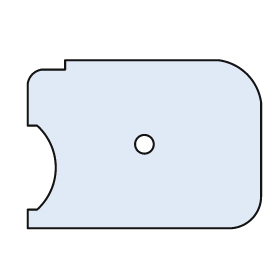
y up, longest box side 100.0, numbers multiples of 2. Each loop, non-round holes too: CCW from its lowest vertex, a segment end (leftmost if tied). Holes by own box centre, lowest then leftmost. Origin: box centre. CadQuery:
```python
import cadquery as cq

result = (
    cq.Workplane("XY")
    .moveTo(-50.0, -36.0)
    .lineTo(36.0, -36.0)
    .threePointArc((46.0, -32.0), (50.0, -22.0))
    .lineTo(50.0, 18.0)
    .threePointArc((44.0, 30.0), (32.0, 36.0))
    .lineTo(-34.0, 36.0)
    .lineTo(-34.0, 32.0)
    .lineTo(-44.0, 32.0)
    .threePointArc((-48.0, 30.0), (-50.0, 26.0))
    .lineTo(-50.0, 8.0)
    .lineTo(-46.0, 8.0)
    .threePointArc((-38.0, -10.0), (-46.0, -28.0))
    .lineTo(-50.0, -28.0)
    .close()
    .moveTo(0.0, 0.0)
    .circle(4.0)
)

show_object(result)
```